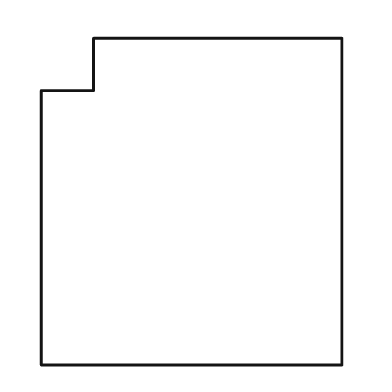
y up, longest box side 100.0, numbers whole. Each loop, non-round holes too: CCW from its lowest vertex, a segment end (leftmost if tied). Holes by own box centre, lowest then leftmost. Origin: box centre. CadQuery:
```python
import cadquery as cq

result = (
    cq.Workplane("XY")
    .moveTo(-46.0, -50.0)
    .lineTo(46.0, -50.0)
    .lineTo(46.0, 50.0)
    .lineTo(-30.0, 50.0)
    .lineTo(-30.0, 34.0)
    .lineTo(-46.0, 34.0)
    .close()
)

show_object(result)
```